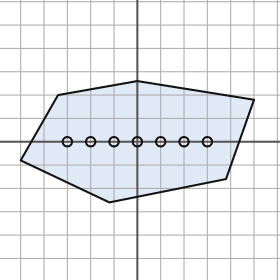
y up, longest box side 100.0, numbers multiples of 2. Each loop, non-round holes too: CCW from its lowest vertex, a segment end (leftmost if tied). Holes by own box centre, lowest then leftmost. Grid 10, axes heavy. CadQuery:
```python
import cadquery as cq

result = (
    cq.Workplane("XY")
    .moveTo(-12.0, -26.0)
    .lineTo(38.0, -16.0)
    .lineTo(50.0, 18.0)
    .lineTo(0.0, 26.0)
    .lineTo(-34.0, 20.0)
    .lineTo(-50.0, -8.0)
    .close()
    .moveTo(-30.0, 0.0)
    .circle(2.0)
    .moveTo(-20.0, 0.0)
    .circle(2.0)
    .moveTo(-10.0, 0.0)
    .circle(2.0)
    .moveTo(0.0, 0.0)
    .circle(2.0)
    .moveTo(10.0, 0.0)
    .circle(2.0)
    .moveTo(20.0, 0.0)
    .circle(2.0)
    .moveTo(30.0, 0.0)
    .circle(2.0)
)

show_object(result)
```